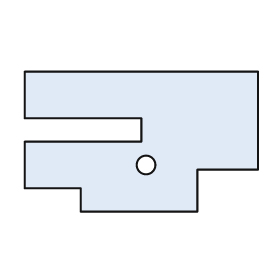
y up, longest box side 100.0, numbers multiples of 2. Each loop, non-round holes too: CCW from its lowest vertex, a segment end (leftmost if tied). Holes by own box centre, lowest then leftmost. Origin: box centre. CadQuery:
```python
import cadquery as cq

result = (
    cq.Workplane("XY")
    .moveTo(-26.0, -30.0)
    .lineTo(24.0, -30.0)
    .lineTo(24.0, -12.0)
    .lineTo(50.0, -12.0)
    .lineTo(50.0, 30.0)
    .lineTo(-50.0, 30.0)
    .lineTo(-50.0, 10.0)
    .lineTo(0.0, 10.0)
    .lineTo(0.0, 0.0)
    .lineTo(-50.0, 0.0)
    .lineTo(-50.0, -20.0)
    .lineTo(-26.0, -20.0)
    .close()
    .moveTo(2.0, -10.0)
    .circle(4.0)
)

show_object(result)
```